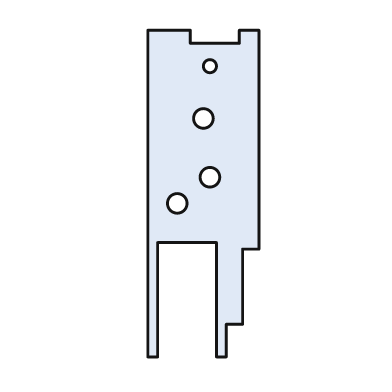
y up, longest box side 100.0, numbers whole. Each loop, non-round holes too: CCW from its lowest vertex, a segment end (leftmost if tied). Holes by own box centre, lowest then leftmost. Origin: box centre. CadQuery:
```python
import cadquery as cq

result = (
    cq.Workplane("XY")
    .moveTo(-17.0, -50.0)
    .lineTo(-14.0, -50.0)
    .lineTo(-14.0, -15.0)
    .lineTo(4.0, -15.0)
    .lineTo(4.0, -50.0)
    .lineTo(7.0, -50.0)
    .lineTo(7.0, -40.0)
    .lineTo(12.0, -40.0)
    .lineTo(12.0, -17.0)
    .lineTo(17.0, -17.0)
    .lineTo(17.0, 50.0)
    .lineTo(11.0, 50.0)
    .lineTo(11.0, 46.0)
    .lineTo(-4.0, 46.0)
    .lineTo(-4.0, 50.0)
    .lineTo(-17.0, 50.0)
    .close()
    .moveTo(-8.0, -3.0)
    .circle(3.0)
    .moveTo(2.0, 5.0)
    .circle(3.0)
    .moveTo(0.0, 23.0)
    .circle(3.0)
    .moveTo(2.0, 39.0)
    .circle(2.0)
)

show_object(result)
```